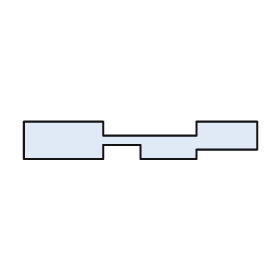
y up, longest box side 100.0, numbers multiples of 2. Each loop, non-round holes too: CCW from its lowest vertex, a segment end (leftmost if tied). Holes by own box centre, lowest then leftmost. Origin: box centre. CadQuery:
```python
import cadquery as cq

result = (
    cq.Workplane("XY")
    .moveTo(-50.0, -8.0)
    .lineTo(-16.0, -8.0)
    .lineTo(-16.0, -2.0)
    .lineTo(0.0, -2.0)
    .lineTo(0.0, -8.0)
    .lineTo(24.0, -8.0)
    .lineTo(24.0, -4.0)
    .lineTo(50.0, -4.0)
    .lineTo(50.0, 8.0)
    .lineTo(24.0, 8.0)
    .lineTo(24.0, 2.0)
    .lineTo(-16.0, 2.0)
    .lineTo(-16.0, 8.0)
    .lineTo(-50.0, 8.0)
    .close()
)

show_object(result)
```